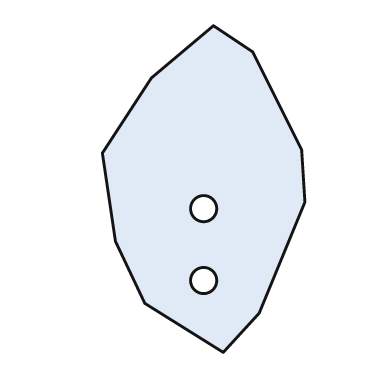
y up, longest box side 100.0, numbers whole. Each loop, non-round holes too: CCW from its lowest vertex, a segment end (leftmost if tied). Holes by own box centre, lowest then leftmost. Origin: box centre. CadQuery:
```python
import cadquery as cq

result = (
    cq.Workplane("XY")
    .moveTo(6.0, -50.0)
    .lineTo(17.0, -38.0)
    .lineTo(31.0, -4.0)
    .lineTo(30.0, 12.0)
    .lineTo(15.0, 42.0)
    .lineTo(3.0, 50.0)
    .lineTo(-16.0, 34.0)
    .lineTo(-31.0, 11.0)
    .lineTo(-27.0, -16.0)
    .lineTo(-18.0, -35.0)
    .close()
    .moveTo(0.0, -28.0)
    .circle(4.0)
    .moveTo(0.0, -6.0)
    .circle(4.0)
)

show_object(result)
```